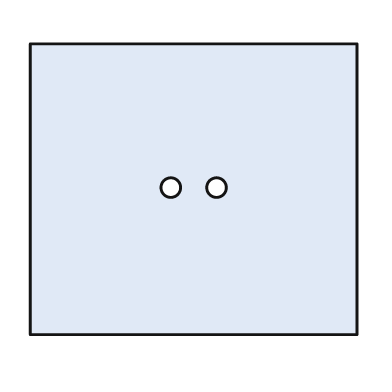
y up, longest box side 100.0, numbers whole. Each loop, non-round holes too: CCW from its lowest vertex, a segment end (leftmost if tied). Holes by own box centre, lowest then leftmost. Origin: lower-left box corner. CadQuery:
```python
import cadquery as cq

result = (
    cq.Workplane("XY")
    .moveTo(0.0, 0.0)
    .lineTo(100.0, 0.0)
    .lineTo(100.0, 89.0)
    .lineTo(0.0, 89.0)
    .close()
    .moveTo(43.0, 45.0)
    .circle(3.0)
    .moveTo(57.0, 45.0)
    .circle(3.0)
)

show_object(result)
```